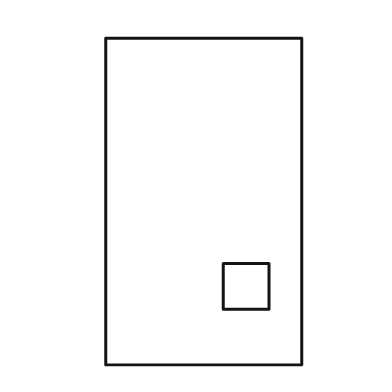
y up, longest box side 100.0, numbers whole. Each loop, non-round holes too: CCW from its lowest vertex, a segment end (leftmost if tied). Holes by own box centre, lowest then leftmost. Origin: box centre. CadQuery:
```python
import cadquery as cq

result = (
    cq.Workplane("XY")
    .moveTo(-30.0, -50.0)
    .lineTo(30.0, -50.0)
    .lineTo(30.0, 50.0)
    .lineTo(-30.0, 50.0)
    .close()
    .moveTo(6.0, -33.0)
    .lineTo(20.0, -33.0)
    .lineTo(20.0, -19.0)
    .lineTo(6.0, -19.0)
    .close()
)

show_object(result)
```